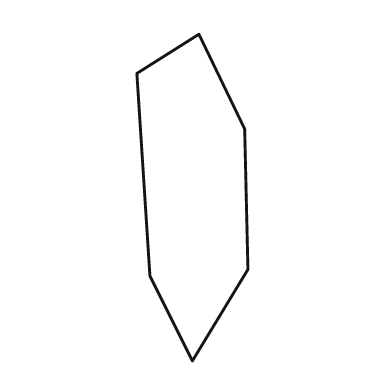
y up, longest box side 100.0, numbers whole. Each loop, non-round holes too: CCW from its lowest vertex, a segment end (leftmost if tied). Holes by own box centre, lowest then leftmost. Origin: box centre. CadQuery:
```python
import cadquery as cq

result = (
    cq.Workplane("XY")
    .moveTo(0.0, -50.0)
    .lineTo(17.0, -22.0)
    .lineTo(16.0, 21.0)
    .lineTo(2.0, 50.0)
    .lineTo(-17.0, 38.0)
    .lineTo(-13.0, -24.0)
    .close()
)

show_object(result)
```